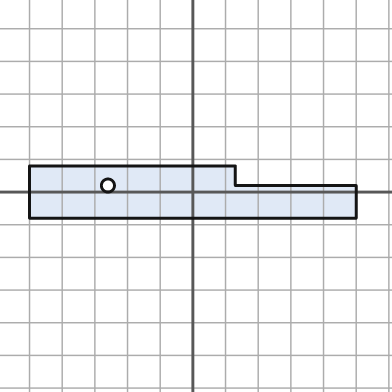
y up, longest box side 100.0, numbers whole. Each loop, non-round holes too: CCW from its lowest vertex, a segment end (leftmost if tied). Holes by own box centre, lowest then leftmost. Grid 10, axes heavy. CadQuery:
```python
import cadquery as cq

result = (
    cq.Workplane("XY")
    .moveTo(-50.0, -8.0)
    .lineTo(50.0, -8.0)
    .lineTo(50.0, 2.0)
    .lineTo(13.0, 2.0)
    .lineTo(13.0, 8.0)
    .lineTo(-50.0, 8.0)
    .close()
    .moveTo(-26.0, 2.0)
    .circle(2.0)
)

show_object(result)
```